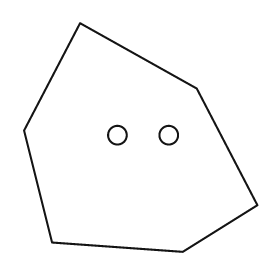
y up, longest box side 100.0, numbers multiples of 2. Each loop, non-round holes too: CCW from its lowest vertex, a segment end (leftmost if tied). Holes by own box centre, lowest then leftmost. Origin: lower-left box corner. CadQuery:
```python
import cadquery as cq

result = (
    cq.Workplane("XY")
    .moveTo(68.0, 0.0)
    .lineTo(100.0, 20.0)
    .lineTo(74.0, 70.0)
    .lineTo(24.0, 98.0)
    .lineTo(0.0, 52.0)
    .lineTo(12.0, 4.0)
    .close()
    .moveTo(40.0, 50.0)
    .circle(4.0)
    .moveTo(62.0, 50.0)
    .circle(4.0)
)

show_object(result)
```